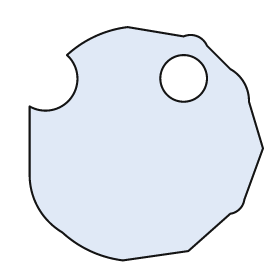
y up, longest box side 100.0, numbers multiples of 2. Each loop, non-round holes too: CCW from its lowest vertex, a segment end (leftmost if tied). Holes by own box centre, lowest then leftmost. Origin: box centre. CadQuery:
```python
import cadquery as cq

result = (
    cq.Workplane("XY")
    .moveTo(-10.0, -50.0)
    .lineTo(18.0, -46.0)
    .lineTo(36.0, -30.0)
    .threePointArc((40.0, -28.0), (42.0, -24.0))
    .lineTo(50.0, -2.0)
    .lineTo(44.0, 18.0)
    .threePointArc((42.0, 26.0), (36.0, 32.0))
    .lineTo(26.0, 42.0)
    .threePointArc((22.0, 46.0), (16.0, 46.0))
    .lineTo(-8.0, 50.0)
    .threePointArc((-22.0, 46.0), (-34.0, 38.0))
    .threePointArc((-32.0, 20.0), (-50.0, 16.0))
    .lineTo(-50.0, -14.0)
    .threePointArc((-46.0, -28.0), (-36.0, -38.0))
    .threePointArc((-24.0, -46.0), (-10.0, -50.0))
    .close()
    .moveTo(16.0, 28.0)
    .circle(10.0)
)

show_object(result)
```